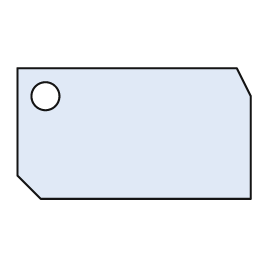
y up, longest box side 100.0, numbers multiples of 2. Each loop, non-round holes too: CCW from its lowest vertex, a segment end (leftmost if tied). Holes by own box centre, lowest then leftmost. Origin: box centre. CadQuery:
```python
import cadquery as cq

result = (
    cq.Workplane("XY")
    .moveTo(-40.0, -28.0)
    .lineTo(50.0, -28.0)
    .lineTo(50.0, 16.0)
    .lineTo(44.0, 28.0)
    .lineTo(-50.0, 28.0)
    .lineTo(-50.0, -18.0)
    .close()
    .moveTo(-38.0, 16.0)
    .circle(6.0)
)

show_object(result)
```